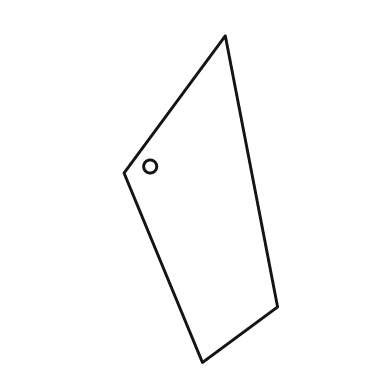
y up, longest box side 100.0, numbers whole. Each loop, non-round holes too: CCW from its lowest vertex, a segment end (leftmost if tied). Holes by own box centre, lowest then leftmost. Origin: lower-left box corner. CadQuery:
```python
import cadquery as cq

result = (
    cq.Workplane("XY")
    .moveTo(24.0, 0.0)
    .lineTo(47.0, 17.0)
    .lineTo(31.0, 100.0)
    .lineTo(0.0, 58.0)
    .close()
    .moveTo(8.0, 60.0)
    .circle(2.0)
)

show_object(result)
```